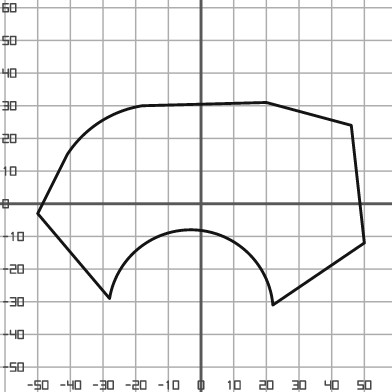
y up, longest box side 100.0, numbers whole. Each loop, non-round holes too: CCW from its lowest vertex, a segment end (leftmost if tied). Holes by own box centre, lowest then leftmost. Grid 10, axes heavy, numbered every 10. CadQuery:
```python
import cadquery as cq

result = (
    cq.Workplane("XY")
    .moveTo(22.0, -31.0)
    .lineTo(50.0, -12.0)
    .lineTo(46.0, 24.0)
    .lineTo(20.0, 31.0)
    .lineTo(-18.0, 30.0)
    .threePointArc((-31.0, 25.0), (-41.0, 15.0))
    .lineTo(-50.0, -3.0)
    .lineTo(-28.0, -29.0)
    .threePointArc((-2.0, -8.0), (22.0, -31.0))
    .close()
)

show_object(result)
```